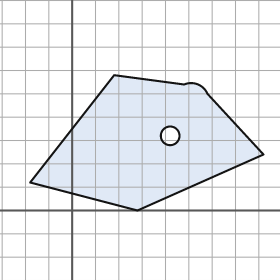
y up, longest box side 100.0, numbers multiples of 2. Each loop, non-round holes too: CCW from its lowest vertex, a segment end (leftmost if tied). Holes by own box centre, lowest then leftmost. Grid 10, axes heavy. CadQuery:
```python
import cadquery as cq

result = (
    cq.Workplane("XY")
    .moveTo(28.0, 0.0)
    .lineTo(82.0, 24.0)
    .lineTo(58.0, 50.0)
    .threePointArc((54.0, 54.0), (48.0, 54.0))
    .lineTo(18.0, 58.0)
    .lineTo(-18.0, 12.0)
    .close()
    .moveTo(42.0, 32.0)
    .circle(4.0)
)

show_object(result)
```